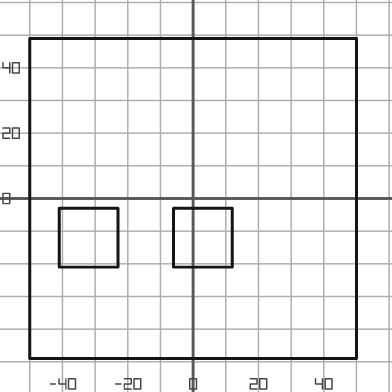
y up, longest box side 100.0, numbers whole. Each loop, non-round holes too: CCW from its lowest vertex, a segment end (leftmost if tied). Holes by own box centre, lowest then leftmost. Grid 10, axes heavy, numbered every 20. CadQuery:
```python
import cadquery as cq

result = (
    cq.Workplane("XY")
    .moveTo(-50.0, -49.0)
    .lineTo(50.0, -49.0)
    .lineTo(50.0, 49.0)
    .lineTo(-50.0, 49.0)
    .close()
    .moveTo(-41.0, -21.0)
    .lineTo(-23.0, -21.0)
    .lineTo(-23.0, -3.0)
    .lineTo(-41.0, -3.0)
    .close()
    .moveTo(-6.0, -21.0)
    .lineTo(12.0, -21.0)
    .lineTo(12.0, -3.0)
    .lineTo(-6.0, -3.0)
    .close()
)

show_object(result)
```